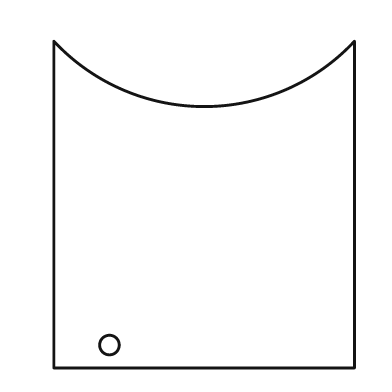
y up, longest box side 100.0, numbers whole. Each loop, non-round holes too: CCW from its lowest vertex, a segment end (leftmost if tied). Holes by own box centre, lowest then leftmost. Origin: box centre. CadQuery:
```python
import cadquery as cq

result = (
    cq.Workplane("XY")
    .moveTo(-46.0, -50.0)
    .lineTo(46.0, -50.0)
    .lineTo(46.0, 50.0)
    .threePointArc((0.0, 30.0), (-46.0, 50.0))
    .close()
    .moveTo(-29.0, -43.0)
    .circle(3.0)
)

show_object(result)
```